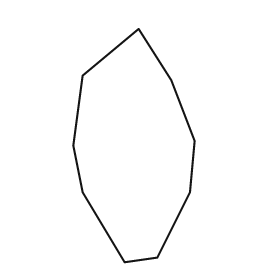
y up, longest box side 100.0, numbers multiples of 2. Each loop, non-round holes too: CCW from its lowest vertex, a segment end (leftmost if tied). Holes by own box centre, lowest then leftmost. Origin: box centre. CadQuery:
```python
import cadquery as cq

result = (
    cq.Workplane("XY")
    .moveTo(-4.0, -50.0)
    .lineTo(10.0, -48.0)
    .lineTo(24.0, -20.0)
    .lineTo(26.0, 2.0)
    .lineTo(16.0, 28.0)
    .lineTo(2.0, 50.0)
    .lineTo(-22.0, 30.0)
    .lineTo(-26.0, 0.0)
    .lineTo(-22.0, -20.0)
    .close()
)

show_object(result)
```